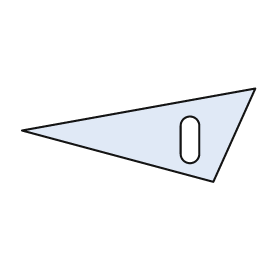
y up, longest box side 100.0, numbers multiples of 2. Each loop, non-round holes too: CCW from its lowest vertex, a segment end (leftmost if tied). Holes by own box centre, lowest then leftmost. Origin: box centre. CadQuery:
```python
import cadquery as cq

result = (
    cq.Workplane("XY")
    .moveTo(32.0, -20.0)
    .lineTo(50.0, 20.0)
    .lineTo(-50.0, 2.0)
    .close()
    .moveTo(18.0, -8.0)
    .threePointArc((22.0, -12.0), (26.0, -8.0))
    .lineTo(26.0, 4.0)
    .threePointArc((22.0, 8.0), (18.0, 4.0))
    .close()
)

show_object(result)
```